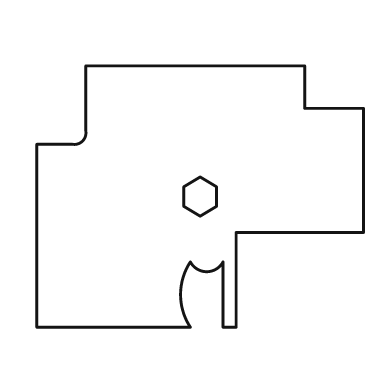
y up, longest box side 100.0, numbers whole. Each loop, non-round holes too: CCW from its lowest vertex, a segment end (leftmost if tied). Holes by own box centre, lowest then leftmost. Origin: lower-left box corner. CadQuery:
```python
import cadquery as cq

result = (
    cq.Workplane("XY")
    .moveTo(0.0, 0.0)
    .lineTo(47.0, 0.0)
    .threePointArc((44.0, 10.0), (47.0, 20.0))
    .threePointArc((52.0, 17.0), (57.0, 20.0))
    .lineTo(57.0, 0.0)
    .lineTo(61.0, 0.0)
    .lineTo(61.0, 29.0)
    .lineTo(100.0, 29.0)
    .lineTo(100.0, 67.0)
    .lineTo(82.0, 67.0)
    .lineTo(82.0, 80.0)
    .lineTo(15.0, 80.0)
    .lineTo(15.0, 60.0)
    .threePointArc((14.0, 57.0), (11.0, 56.0))
    .lineTo(0.0, 56.0)
    .close()
    .moveTo(50.0, 34.0)
    .lineTo(55.0, 37.0)
    .lineTo(55.0, 43.0)
    .lineTo(50.0, 46.0)
    .lineTo(45.0, 43.0)
    .lineTo(45.0, 37.0)
    .close()
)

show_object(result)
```